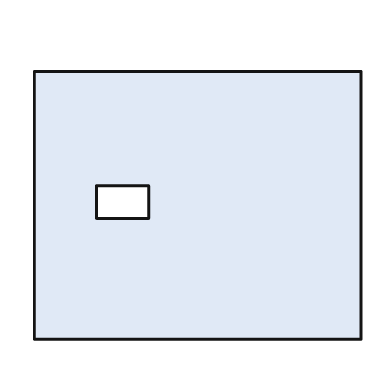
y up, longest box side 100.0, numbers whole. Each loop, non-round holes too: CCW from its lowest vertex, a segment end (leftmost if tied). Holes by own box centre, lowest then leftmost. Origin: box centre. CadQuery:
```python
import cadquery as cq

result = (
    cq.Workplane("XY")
    .moveTo(-50.0, -41.0)
    .lineTo(50.0, -41.0)
    .lineTo(50.0, 41.0)
    .lineTo(-50.0, 41.0)
    .close()
    .moveTo(-31.0, -4.0)
    .lineTo(-15.0, -4.0)
    .lineTo(-15.0, 6.0)
    .lineTo(-31.0, 6.0)
    .close()
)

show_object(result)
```